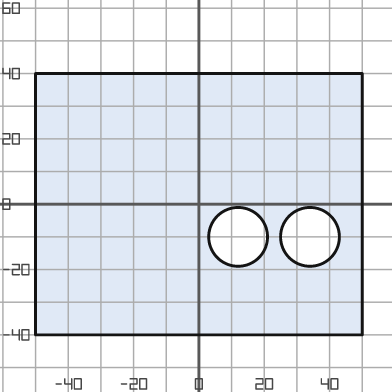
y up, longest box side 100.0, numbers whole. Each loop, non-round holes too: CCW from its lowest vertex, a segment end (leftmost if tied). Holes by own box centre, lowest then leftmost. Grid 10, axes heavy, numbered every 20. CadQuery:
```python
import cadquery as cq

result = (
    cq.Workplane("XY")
    .moveTo(-50.0, -40.0)
    .lineTo(50.0, -40.0)
    .lineTo(50.0, 40.0)
    .lineTo(-50.0, 40.0)
    .close()
    .moveTo(12.0, -10.0)
    .circle(9.0)
    .moveTo(34.0, -10.0)
    .circle(9.0)
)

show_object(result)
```